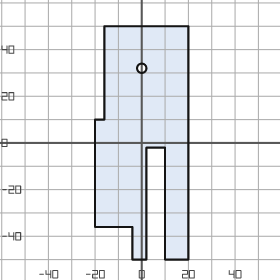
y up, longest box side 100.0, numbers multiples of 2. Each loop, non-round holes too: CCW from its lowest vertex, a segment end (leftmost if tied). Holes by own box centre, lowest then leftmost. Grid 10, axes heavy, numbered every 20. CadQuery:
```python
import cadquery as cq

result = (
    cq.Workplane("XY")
    .moveTo(-4.0, -50.0)
    .lineTo(2.0, -50.0)
    .lineTo(2.0, -2.0)
    .lineTo(10.0, -2.0)
    .lineTo(10.0, -50.0)
    .lineTo(20.0, -50.0)
    .lineTo(20.0, 50.0)
    .lineTo(-16.0, 50.0)
    .lineTo(-16.0, 10.0)
    .lineTo(-20.0, 10.0)
    .lineTo(-20.0, -36.0)
    .lineTo(-4.0, -36.0)
    .close()
    .moveTo(0.0, 32.0)
    .circle(2.0)
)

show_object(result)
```